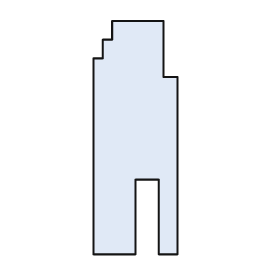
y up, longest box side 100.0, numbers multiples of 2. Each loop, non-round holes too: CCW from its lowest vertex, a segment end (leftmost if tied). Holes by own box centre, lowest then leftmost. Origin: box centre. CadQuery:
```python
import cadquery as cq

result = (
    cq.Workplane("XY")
    .moveTo(-18.0, -50.0)
    .lineTo(0.0, -50.0)
    .lineTo(0.0, -18.0)
    .lineTo(10.0, -18.0)
    .lineTo(10.0, -50.0)
    .lineTo(18.0, -50.0)
    .lineTo(18.0, 26.0)
    .lineTo(12.0, 26.0)
    .lineTo(12.0, 50.0)
    .lineTo(-10.0, 50.0)
    .lineTo(-10.0, 42.0)
    .lineTo(-14.0, 42.0)
    .lineTo(-14.0, 34.0)
    .lineTo(-18.0, 34.0)
    .close()
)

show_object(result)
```